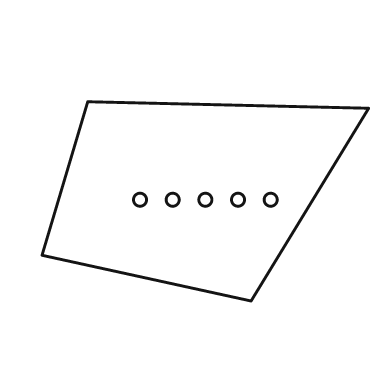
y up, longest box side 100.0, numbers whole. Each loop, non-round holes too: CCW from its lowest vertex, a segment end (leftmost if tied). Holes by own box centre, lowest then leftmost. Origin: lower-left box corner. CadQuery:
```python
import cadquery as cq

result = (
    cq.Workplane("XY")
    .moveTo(64.0, 0.0)
    .lineTo(100.0, 59.0)
    .lineTo(14.0, 61.0)
    .lineTo(0.0, 14.0)
    .close()
    .moveTo(30.0, 31.0)
    .circle(2.0)
    .moveTo(40.0, 31.0)
    .circle(2.0)
    .moveTo(50.0, 31.0)
    .circle(2.0)
    .moveTo(60.0, 31.0)
    .circle(2.0)
    .moveTo(70.0, 31.0)
    .circle(2.0)
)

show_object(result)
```